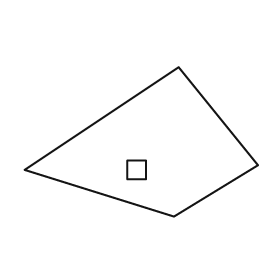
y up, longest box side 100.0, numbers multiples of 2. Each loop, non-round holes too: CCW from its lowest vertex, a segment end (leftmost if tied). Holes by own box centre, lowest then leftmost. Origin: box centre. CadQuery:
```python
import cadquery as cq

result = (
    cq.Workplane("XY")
    .moveTo(14.0, -32.0)
    .lineTo(50.0, -10.0)
    .lineTo(16.0, 32.0)
    .lineTo(-50.0, -12.0)
    .close()
    .moveTo(-6.0, -16.0)
    .lineTo(2.0, -16.0)
    .lineTo(2.0, -8.0)
    .lineTo(-6.0, -8.0)
    .close()
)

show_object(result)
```